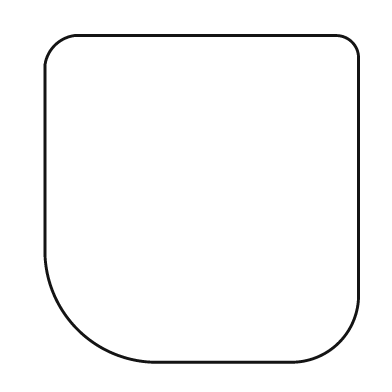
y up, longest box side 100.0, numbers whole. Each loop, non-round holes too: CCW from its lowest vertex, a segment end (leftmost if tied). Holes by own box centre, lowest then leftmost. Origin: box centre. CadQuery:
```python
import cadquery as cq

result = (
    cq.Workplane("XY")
    .moveTo(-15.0, -50.0)
    .lineTo(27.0, -50.0)
    .threePointArc((42.0, -44.0), (48.0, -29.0))
    .lineTo(48.0, 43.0)
    .threePointArc((46.0, 48.0), (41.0, 50.0))
    .lineTo(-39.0, 50.0)
    .threePointArc((-45.0, 47.0), (-48.0, 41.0))
    .lineTo(-48.0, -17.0)
    .threePointArc((-38.0, -40.0), (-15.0, -50.0))
    .close()
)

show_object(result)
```